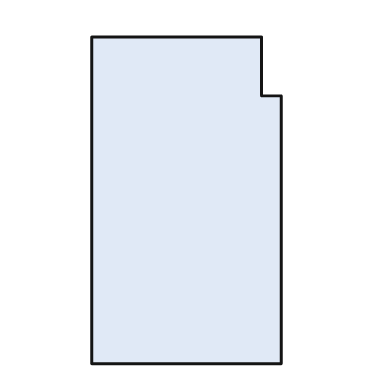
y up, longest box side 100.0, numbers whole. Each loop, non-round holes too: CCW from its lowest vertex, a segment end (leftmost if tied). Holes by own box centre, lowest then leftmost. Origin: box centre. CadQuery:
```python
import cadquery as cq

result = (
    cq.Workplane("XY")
    .moveTo(-29.0, -50.0)
    .lineTo(29.0, -50.0)
    .lineTo(29.0, 32.0)
    .lineTo(23.0, 32.0)
    .lineTo(23.0, 50.0)
    .lineTo(-29.0, 50.0)
    .close()
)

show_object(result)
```